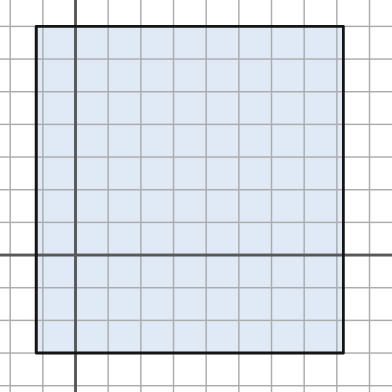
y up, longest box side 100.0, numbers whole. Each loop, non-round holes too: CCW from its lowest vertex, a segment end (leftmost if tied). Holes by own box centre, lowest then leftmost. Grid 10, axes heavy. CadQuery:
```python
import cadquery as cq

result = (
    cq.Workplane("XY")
    .moveTo(-12.0, -30.0)
    .lineTo(82.0, -30.0)
    .lineTo(82.0, 70.0)
    .lineTo(-12.0, 70.0)
    .close()
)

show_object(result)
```